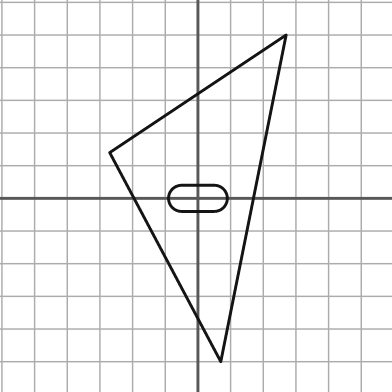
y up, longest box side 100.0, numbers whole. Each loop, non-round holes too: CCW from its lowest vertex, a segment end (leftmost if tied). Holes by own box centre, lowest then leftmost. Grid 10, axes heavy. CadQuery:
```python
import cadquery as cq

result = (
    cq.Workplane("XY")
    .moveTo(7.0, -50.0)
    .lineTo(27.0, 50.0)
    .lineTo(-27.0, 14.0)
    .close()
    .moveTo(-5.0, -4.0)
    .lineTo(5.0, -4.0)
    .threePointArc((9.0, 0.0), (5.0, 4.0))
    .lineTo(-5.0, 4.0)
    .threePointArc((-9.0, 0.0), (-5.0, -4.0))
    .close()
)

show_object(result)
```